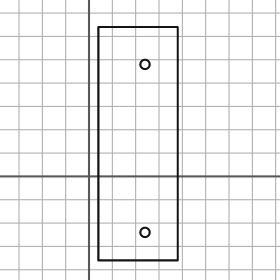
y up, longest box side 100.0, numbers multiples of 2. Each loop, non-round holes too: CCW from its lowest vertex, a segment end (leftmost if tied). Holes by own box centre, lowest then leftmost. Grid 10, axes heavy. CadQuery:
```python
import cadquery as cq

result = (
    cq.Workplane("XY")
    .moveTo(4.0, -36.0)
    .lineTo(38.0, -36.0)
    .lineTo(38.0, 64.0)
    .lineTo(4.0, 64.0)
    .close()
    .moveTo(24.0, -24.0)
    .circle(2.0)
    .moveTo(24.0, 48.0)
    .circle(2.0)
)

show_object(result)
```